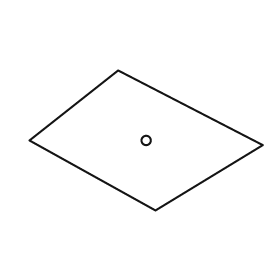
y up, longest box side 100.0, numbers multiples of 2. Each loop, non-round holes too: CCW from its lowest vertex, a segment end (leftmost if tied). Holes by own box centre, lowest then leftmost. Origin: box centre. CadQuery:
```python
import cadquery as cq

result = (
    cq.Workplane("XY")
    .moveTo(4.0, -30.0)
    .lineTo(50.0, -2.0)
    .lineTo(-12.0, 30.0)
    .lineTo(-50.0, 0.0)
    .close()
    .moveTo(0.0, 0.0)
    .circle(2.0)
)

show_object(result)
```